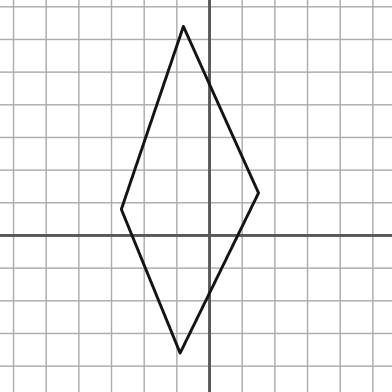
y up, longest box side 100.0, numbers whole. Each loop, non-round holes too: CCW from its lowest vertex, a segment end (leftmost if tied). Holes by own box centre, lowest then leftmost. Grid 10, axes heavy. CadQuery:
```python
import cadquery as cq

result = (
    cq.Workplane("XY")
    .moveTo(-9.0, -36.0)
    .lineTo(15.0, 13.0)
    .lineTo(-8.0, 64.0)
    .lineTo(-27.0, 8.0)
    .close()
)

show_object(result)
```